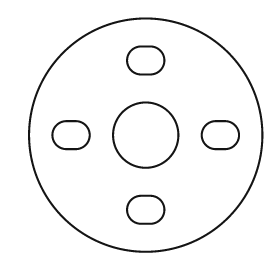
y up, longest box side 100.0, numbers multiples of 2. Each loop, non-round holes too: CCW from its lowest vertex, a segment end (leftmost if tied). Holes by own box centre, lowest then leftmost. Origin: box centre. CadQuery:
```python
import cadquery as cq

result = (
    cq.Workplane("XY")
    .moveTo(0.0, 0.0)
    .circle(50.0)
    .moveTo(-2.0, -38.0)
    .lineTo(2.0, -38.0)
    .threePointArc((8.0, -32.0), (2.0, -26.0))
    .lineTo(-2.0, -26.0)
    .threePointArc((-8.0, -32.0), (-2.0, -38.0))
    .close()
    .moveTo(-34.0, -6.0)
    .lineTo(-30.0, -6.0)
    .threePointArc((-24.0, 0.0), (-30.0, 6.0))
    .lineTo(-34.0, 6.0)
    .threePointArc((-40.0, 0.0), (-34.0, -6.0))
    .close()
    .moveTo(0.0, 0.0)
    .circle(14.0)
    .moveTo(30.0, -6.0)
    .lineTo(34.0, -6.0)
    .threePointArc((40.0, 0.0), (34.0, 6.0))
    .lineTo(30.0, 6.0)
    .threePointArc((24.0, 0.0), (30.0, -6.0))
    .close()
    .moveTo(-2.0, 26.0)
    .lineTo(2.0, 26.0)
    .threePointArc((8.0, 32.0), (2.0, 38.0))
    .lineTo(-2.0, 38.0)
    .threePointArc((-8.0, 32.0), (-2.0, 26.0))
    .close()
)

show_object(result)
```